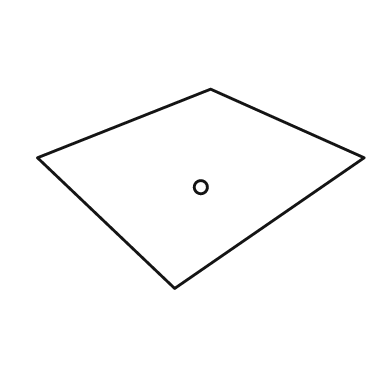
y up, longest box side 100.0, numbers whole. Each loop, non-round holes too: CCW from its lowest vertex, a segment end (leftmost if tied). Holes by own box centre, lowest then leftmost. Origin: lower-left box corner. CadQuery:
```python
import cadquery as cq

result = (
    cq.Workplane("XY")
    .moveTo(42.0, 0.0)
    .lineTo(100.0, 40.0)
    .lineTo(53.0, 61.0)
    .lineTo(0.0, 40.0)
    .close()
    .moveTo(50.0, 31.0)
    .circle(2.0)
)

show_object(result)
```